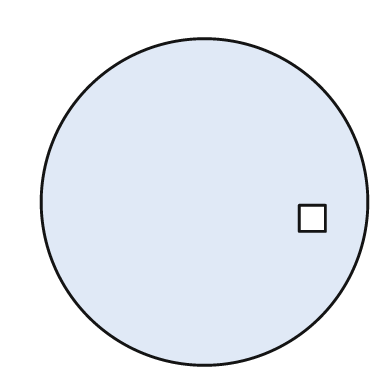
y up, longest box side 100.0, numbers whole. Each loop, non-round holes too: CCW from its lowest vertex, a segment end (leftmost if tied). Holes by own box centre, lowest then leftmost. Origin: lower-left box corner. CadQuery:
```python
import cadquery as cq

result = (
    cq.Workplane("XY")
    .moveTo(50.0, 50.0)
    .circle(50.0)
    .moveTo(79.0, 41.0)
    .lineTo(87.0, 41.0)
    .lineTo(87.0, 49.0)
    .lineTo(79.0, 49.0)
    .close()
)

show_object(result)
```